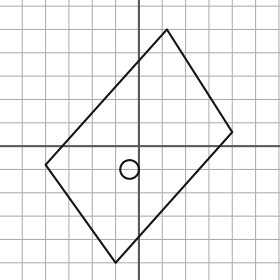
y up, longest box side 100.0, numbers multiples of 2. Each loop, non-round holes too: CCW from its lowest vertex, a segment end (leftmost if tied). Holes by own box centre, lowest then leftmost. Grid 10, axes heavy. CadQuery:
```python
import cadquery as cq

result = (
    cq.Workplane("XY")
    .moveTo(-10.0, -50.0)
    .lineTo(40.0, 6.0)
    .lineTo(12.0, 50.0)
    .lineTo(-40.0, -8.0)
    .close()
    .moveTo(-4.0, -10.0)
    .circle(4.0)
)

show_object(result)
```